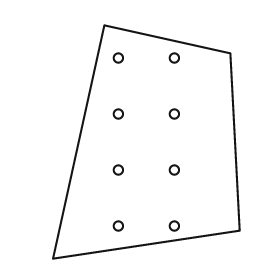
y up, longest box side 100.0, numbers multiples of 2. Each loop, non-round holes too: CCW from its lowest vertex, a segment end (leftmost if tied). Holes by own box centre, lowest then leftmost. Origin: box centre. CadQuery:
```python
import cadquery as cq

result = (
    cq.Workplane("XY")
    .moveTo(-40.0, -50.0)
    .lineTo(40.0, -38.0)
    .lineTo(36.0, 38.0)
    .lineTo(-18.0, 50.0)
    .close()
    .moveTo(-12.0, -36.0)
    .circle(2.0)
    .moveTo(12.0, -36.0)
    .circle(2.0)
    .moveTo(-12.0, -12.0)
    .circle(2.0)
    .moveTo(12.0, -12.0)
    .circle(2.0)
    .moveTo(-12.0, 12.0)
    .circle(2.0)
    .moveTo(12.0, 12.0)
    .circle(2.0)
    .moveTo(-12.0, 36.0)
    .circle(2.0)
    .moveTo(12.0, 36.0)
    .circle(2.0)
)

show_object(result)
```